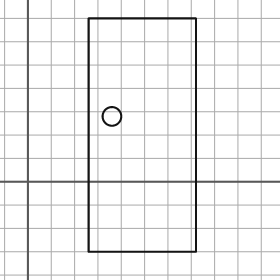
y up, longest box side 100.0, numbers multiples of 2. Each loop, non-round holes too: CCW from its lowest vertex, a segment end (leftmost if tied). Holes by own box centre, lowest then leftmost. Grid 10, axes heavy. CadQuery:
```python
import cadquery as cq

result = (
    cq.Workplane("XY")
    .moveTo(26.0, -30.0)
    .lineTo(72.0, -30.0)
    .lineTo(72.0, 70.0)
    .lineTo(26.0, 70.0)
    .close()
    .moveTo(36.0, 28.0)
    .circle(4.0)
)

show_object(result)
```